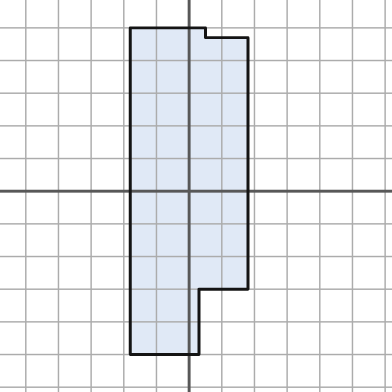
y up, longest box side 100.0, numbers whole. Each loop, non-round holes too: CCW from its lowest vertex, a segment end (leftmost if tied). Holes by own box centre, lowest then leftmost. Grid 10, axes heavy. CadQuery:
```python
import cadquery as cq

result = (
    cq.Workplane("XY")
    .moveTo(-18.0, -50.0)
    .lineTo(3.0, -50.0)
    .lineTo(3.0, -30.0)
    .lineTo(18.0, -30.0)
    .lineTo(18.0, 47.0)
    .lineTo(5.0, 47.0)
    .lineTo(5.0, 50.0)
    .lineTo(-18.0, 50.0)
    .close()
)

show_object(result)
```